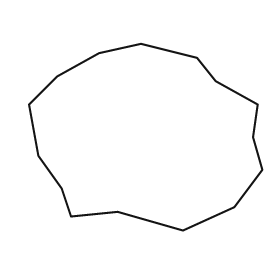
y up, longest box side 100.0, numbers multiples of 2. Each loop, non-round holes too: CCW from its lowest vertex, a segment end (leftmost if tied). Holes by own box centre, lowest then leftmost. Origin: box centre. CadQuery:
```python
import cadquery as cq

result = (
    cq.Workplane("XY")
    .moveTo(16.0, -40.0)
    .lineTo(38.0, -30.0)
    .lineTo(50.0, -14.0)
    .lineTo(46.0, 0.0)
    .lineTo(48.0, 14.0)
    .lineTo(30.0, 24.0)
    .lineTo(22.0, 34.0)
    .lineTo(-2.0, 40.0)
    .lineTo(-20.0, 36.0)
    .lineTo(-38.0, 26.0)
    .lineTo(-50.0, 14.0)
    .lineTo(-46.0, -8.0)
    .lineTo(-36.0, -22.0)
    .lineTo(-32.0, -34.0)
    .lineTo(-12.0, -32.0)
    .close()
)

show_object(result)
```